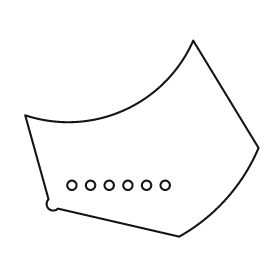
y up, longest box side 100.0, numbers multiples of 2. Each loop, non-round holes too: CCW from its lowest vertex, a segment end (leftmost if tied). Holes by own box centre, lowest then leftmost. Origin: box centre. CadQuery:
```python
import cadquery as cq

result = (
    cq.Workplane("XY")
    .moveTo(16.0, -42.0)
    .threePointArc((36.0, -26.0), (50.0, -4.0))
    .lineTo(22.0, 42.0)
    .threePointArc((-8.0, 12.0), (-50.0, 10.0))
    .lineTo(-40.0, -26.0)
    .threePointArc((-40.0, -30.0), (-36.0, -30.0))
    .close()
    .moveTo(-30.0, -20.0)
    .circle(2.0)
    .moveTo(-22.0, -20.0)
    .circle(2.0)
    .moveTo(-14.0, -20.0)
    .circle(2.0)
    .moveTo(-6.0, -20.0)
    .circle(2.0)
    .moveTo(2.0, -20.0)
    .circle(2.0)
    .moveTo(10.0, -20.0)
    .circle(2.0)
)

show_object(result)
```